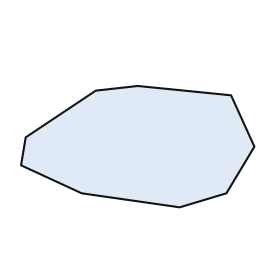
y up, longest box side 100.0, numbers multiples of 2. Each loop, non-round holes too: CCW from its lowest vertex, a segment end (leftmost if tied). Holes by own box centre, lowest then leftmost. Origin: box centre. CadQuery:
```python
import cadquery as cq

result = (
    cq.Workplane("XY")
    .moveTo(18.0, -26.0)
    .lineTo(38.0, -20.0)
    .lineTo(50.0, 0.0)
    .lineTo(40.0, 22.0)
    .lineTo(0.0, 26.0)
    .lineTo(-18.0, 24.0)
    .lineTo(-48.0, 4.0)
    .lineTo(-50.0, -8.0)
    .lineTo(-24.0, -20.0)
    .close()
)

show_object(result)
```